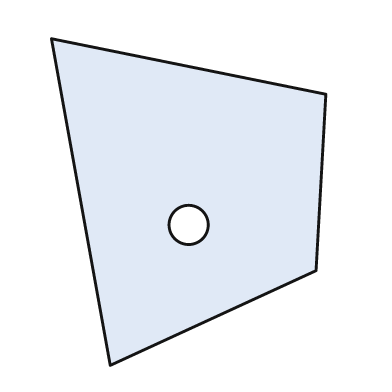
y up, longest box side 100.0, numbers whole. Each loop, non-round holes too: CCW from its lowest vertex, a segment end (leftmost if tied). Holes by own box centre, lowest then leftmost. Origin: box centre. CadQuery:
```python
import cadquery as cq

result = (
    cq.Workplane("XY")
    .moveTo(-24.0, -50.0)
    .lineTo(39.0, -21.0)
    .lineTo(42.0, 33.0)
    .lineTo(-42.0, 50.0)
    .close()
    .moveTo(0.0, -7.0)
    .circle(6.0)
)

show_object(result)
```